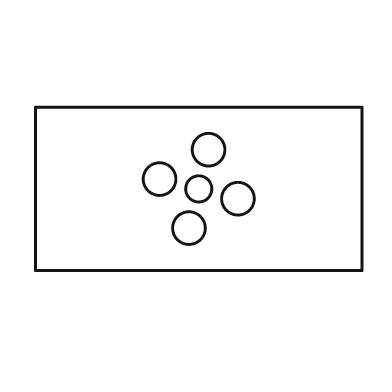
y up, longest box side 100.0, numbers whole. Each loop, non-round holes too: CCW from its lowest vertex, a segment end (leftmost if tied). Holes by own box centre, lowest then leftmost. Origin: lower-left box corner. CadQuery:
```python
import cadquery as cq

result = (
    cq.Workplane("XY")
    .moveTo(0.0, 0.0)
    .lineTo(100.0, 0.0)
    .lineTo(100.0, 50.0)
    .lineTo(0.0, 50.0)
    .close()
    .moveTo(47.0, 13.0)
    .circle(5.0)
    .moveTo(62.0, 22.0)
    .circle(5.0)
    .moveTo(50.0, 25.0)
    .circle(4.0)
    .moveTo(38.0, 28.0)
    .circle(5.0)
    .moveTo(53.0, 37.0)
    .circle(5.0)
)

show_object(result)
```